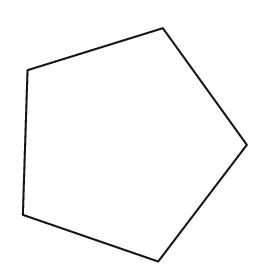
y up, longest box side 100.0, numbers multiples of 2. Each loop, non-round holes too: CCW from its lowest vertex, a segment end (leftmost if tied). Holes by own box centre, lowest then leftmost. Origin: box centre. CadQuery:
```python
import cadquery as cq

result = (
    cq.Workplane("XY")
    .moveTo(10.0, -50.0)
    .lineTo(48.0, 0.0)
    .lineTo(12.0, 50.0)
    .lineTo(-46.0, 32.0)
    .lineTo(-48.0, -30.0)
    .close()
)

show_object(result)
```